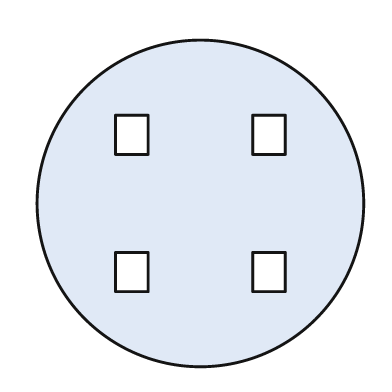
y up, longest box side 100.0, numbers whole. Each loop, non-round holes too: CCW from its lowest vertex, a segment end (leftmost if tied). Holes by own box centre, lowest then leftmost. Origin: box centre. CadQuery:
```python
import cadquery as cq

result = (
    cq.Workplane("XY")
    .moveTo(0.0, 0.0)
    .circle(50.0)
    .moveTo(-26.0, -27.0)
    .lineTo(-16.0, -27.0)
    .lineTo(-16.0, -15.0)
    .lineTo(-26.0, -15.0)
    .close()
    .moveTo(16.0, -27.0)
    .lineTo(26.0, -27.0)
    .lineTo(26.0, -15.0)
    .lineTo(16.0, -15.0)
    .close()
    .moveTo(-26.0, 15.0)
    .lineTo(-16.0, 15.0)
    .lineTo(-16.0, 27.0)
    .lineTo(-26.0, 27.0)
    .close()
    .moveTo(16.0, 15.0)
    .lineTo(26.0, 15.0)
    .lineTo(26.0, 27.0)
    .lineTo(16.0, 27.0)
    .close()
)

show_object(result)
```